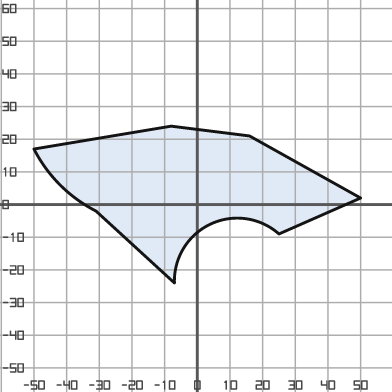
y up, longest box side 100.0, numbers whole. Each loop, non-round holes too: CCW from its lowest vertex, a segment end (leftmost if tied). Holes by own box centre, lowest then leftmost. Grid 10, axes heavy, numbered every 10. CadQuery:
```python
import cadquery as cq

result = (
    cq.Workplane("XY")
    .moveTo(-7.0, -24.0)
    .threePointArc((4.0, -6.0), (25.0, -9.0))
    .lineTo(50.0, 2.0)
    .lineTo(16.0, 21.0)
    .lineTo(-8.0, 24.0)
    .lineTo(-50.0, 17.0)
    .threePointArc((-42.0, 6.0), (-31.0, -2.0))
    .close()
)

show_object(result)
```